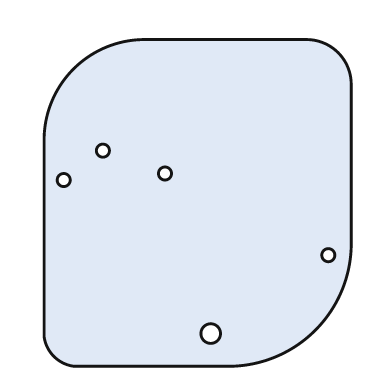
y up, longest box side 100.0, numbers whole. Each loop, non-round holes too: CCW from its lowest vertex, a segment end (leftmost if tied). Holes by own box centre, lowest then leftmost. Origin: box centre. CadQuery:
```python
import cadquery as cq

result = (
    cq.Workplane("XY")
    .moveTo(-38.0, -50.0)
    .lineTo(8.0, -50.0)
    .threePointArc((36.0, -39.0), (47.0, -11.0))
    .lineTo(47.0, 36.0)
    .threePointArc((43.0, 46.0), (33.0, 50.0))
    .lineTo(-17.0, 50.0)
    .threePointArc((-38.0, 41.0), (-47.0, 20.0))
    .lineTo(-47.0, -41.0)
    .threePointArc((-44.0, -47.0), (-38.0, -50.0))
    .close()
    .moveTo(4.0, -40.0)
    .circle(3.0)
    .moveTo(40.0, -16.0)
    .circle(2.0)
    .moveTo(-41.0, 7.0)
    .circle(2.0)
    .moveTo(-10.0, 9.0)
    .circle(2.0)
    .moveTo(-29.0, 16.0)
    .circle(2.0)
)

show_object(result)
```